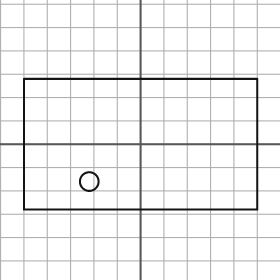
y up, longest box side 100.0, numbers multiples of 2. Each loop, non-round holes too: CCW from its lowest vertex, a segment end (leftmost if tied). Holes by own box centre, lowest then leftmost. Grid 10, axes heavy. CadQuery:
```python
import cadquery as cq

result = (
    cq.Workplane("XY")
    .moveTo(-50.0, -28.0)
    .lineTo(50.0, -28.0)
    .lineTo(50.0, 28.0)
    .lineTo(-50.0, 28.0)
    .close()
    .moveTo(-22.0, -16.0)
    .circle(4.0)
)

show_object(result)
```